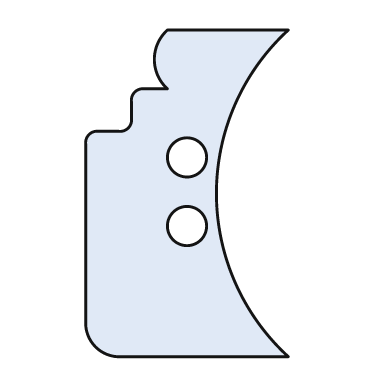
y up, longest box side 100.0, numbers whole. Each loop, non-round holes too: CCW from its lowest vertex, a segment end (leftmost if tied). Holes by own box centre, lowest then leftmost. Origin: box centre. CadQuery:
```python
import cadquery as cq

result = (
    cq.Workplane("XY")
    .moveTo(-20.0, -50.0)
    .lineTo(31.0, -50.0)
    .threePointArc((9.0, 0.0), (31.0, 50.0))
    .lineTo(-6.0, 50.0)
    .threePointArc((-10.0, 41.0), (-6.0, 32.0))
    .lineTo(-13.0, 32.0)
    .threePointArc((-16.0, 31.0), (-17.0, 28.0))
    .lineTo(-17.0, 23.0)
    .threePointArc((-18.0, 20.0), (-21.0, 19.0))
    .lineTo(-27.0, 19.0)
    .threePointArc((-30.0, 18.0), (-31.0, 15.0))
    .lineTo(-31.0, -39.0)
    .threePointArc((-28.0, -47.0), (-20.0, -50.0))
    .close()
    .moveTo(0.0, -10.0)
    .circle(6.0)
    .moveTo(0.0, 11.0)
    .circle(6.0)
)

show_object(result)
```